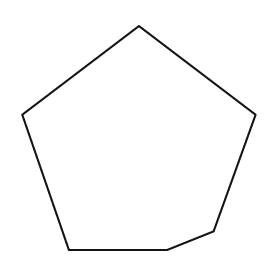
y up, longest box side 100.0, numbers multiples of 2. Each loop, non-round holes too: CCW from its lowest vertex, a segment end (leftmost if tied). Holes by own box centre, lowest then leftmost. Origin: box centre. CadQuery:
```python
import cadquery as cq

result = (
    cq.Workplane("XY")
    .moveTo(-30.0, -48.0)
    .lineTo(12.0, -48.0)
    .lineTo(32.0, -40.0)
    .lineTo(50.0, 10.0)
    .lineTo(0.0, 48.0)
    .lineTo(-50.0, 10.0)
    .close()
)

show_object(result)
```